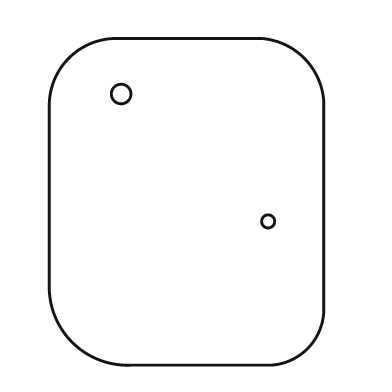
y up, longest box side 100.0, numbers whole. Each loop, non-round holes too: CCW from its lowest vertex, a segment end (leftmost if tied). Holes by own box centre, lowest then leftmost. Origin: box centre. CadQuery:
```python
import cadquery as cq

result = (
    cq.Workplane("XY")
    .moveTo(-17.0, -50.0)
    .lineTo(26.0, -50.0)
    .threePointArc((37.0, -45.0), (42.0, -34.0))
    .lineTo(42.0, 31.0)
    .threePointArc((36.0, 44.0), (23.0, 50.0))
    .lineTo(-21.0, 50.0)
    .threePointArc((-36.0, 44.0), (-42.0, 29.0))
    .lineTo(-42.0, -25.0)
    .threePointArc((-35.0, -43.0), (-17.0, -50.0))
    .close()
    .moveTo(25.0, -6.0)
    .circle(2.0)
    .moveTo(-20.0, 33.0)
    .circle(3.0)
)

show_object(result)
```